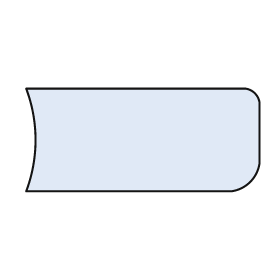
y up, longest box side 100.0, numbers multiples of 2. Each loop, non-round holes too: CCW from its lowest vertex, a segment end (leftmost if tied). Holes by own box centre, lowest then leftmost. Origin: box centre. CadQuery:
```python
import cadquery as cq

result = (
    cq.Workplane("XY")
    .moveTo(-50.0, -22.0)
    .lineTo(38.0, -22.0)
    .threePointArc((46.0, -18.0), (50.0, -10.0))
    .lineTo(50.0, 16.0)
    .threePointArc((48.0, 20.0), (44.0, 22.0))
    .lineTo(-50.0, 22.0)
    .threePointArc((-46.0, 0.0), (-50.0, -22.0))
    .close()
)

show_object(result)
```